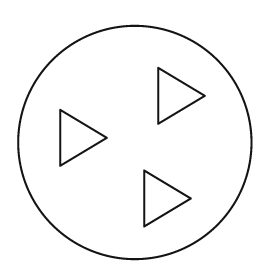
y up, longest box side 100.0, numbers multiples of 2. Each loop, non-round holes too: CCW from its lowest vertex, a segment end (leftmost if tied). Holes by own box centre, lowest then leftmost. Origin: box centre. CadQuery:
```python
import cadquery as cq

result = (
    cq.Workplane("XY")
    .moveTo(0.0, 0.0)
    .circle(50.0)
    .moveTo(4.0, -36.0)
    .lineTo(24.0, -24.0)
    .lineTo(4.0, -12.0)
    .close()
    .moveTo(-32.0, -10.0)
    .lineTo(-12.0, 2.0)
    .lineTo(-32.0, 14.0)
    .close()
    .moveTo(10.0, 8.0)
    .lineTo(30.0, 20.0)
    .lineTo(10.0, 32.0)
    .close()
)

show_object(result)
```